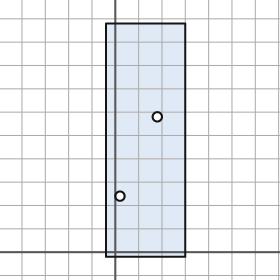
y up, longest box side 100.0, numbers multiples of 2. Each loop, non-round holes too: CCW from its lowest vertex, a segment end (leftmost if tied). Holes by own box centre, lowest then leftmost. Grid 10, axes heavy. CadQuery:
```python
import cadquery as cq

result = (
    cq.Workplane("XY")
    .moveTo(-4.0, -2.0)
    .lineTo(30.0, -2.0)
    .lineTo(30.0, 98.0)
    .lineTo(-4.0, 98.0)
    .close()
    .moveTo(2.0, 24.0)
    .circle(2.0)
    .moveTo(18.0, 58.0)
    .circle(2.0)
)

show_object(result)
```